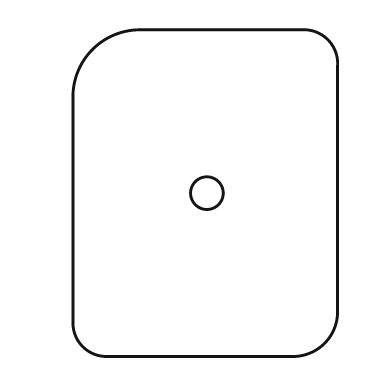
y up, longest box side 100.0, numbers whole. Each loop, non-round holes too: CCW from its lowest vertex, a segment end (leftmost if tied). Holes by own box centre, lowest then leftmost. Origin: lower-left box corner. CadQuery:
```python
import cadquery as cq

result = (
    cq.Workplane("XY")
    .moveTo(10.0, 0.0)
    .lineTo(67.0, 0.0)
    .threePointArc((77.0, 4.0), (81.0, 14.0))
    .lineTo(81.0, 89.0)
    .threePointArc((78.0, 97.0), (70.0, 100.0))
    .lineTo(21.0, 100.0)
    .threePointArc((6.0, 94.0), (0.0, 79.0))
    .lineTo(0.0, 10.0)
    .threePointArc((3.0, 3.0), (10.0, 0.0))
    .close()
    .moveTo(41.0, 50.0)
    .circle(5.0)
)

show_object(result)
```